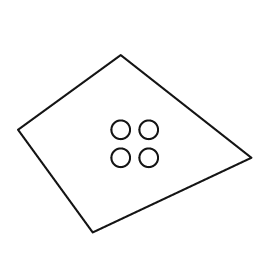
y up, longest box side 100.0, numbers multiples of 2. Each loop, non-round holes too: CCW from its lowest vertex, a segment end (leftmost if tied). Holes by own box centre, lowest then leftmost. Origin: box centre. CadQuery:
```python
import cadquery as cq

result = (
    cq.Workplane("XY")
    .moveTo(-18.0, -38.0)
    .lineTo(50.0, -6.0)
    .lineTo(-6.0, 38.0)
    .lineTo(-50.0, 6.0)
    .close()
    .moveTo(-6.0, -6.0)
    .circle(4.0)
    .moveTo(6.0, -6.0)
    .circle(4.0)
    .moveTo(-6.0, 6.0)
    .circle(4.0)
    .moveTo(6.0, 6.0)
    .circle(4.0)
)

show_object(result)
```